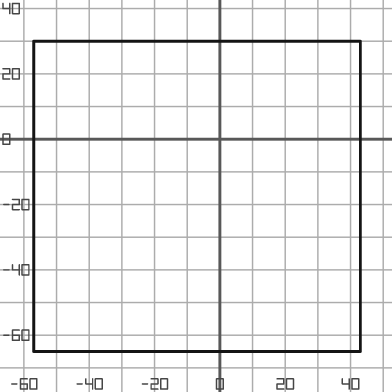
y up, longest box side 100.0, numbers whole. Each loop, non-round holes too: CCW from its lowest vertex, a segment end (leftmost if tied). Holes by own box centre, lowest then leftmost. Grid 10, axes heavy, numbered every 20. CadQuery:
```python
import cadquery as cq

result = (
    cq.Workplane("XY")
    .moveTo(-57.0, -65.0)
    .lineTo(43.0, -65.0)
    .lineTo(43.0, 30.0)
    .lineTo(-57.0, 30.0)
    .close()
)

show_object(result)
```